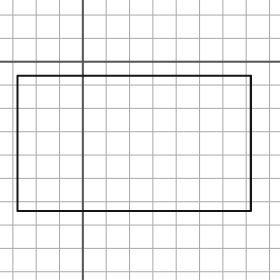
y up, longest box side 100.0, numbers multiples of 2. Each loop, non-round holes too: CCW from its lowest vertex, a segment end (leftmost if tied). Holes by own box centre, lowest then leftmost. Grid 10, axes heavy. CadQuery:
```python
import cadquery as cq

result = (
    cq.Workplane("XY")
    .moveTo(-28.0, -64.0)
    .lineTo(72.0, -64.0)
    .lineTo(72.0, -6.0)
    .lineTo(-28.0, -6.0)
    .close()
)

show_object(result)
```